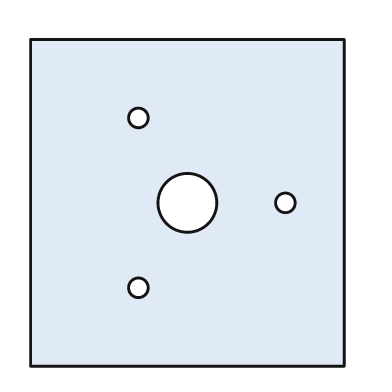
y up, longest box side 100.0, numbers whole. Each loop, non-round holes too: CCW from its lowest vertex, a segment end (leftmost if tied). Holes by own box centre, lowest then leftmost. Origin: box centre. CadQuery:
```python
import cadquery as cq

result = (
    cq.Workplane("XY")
    .moveTo(-48.0, -50.0)
    .lineTo(48.0, -50.0)
    .lineTo(48.0, 50.0)
    .lineTo(-48.0, 50.0)
    .close()
    .moveTo(-15.0, -26.0)
    .circle(3.0)
    .moveTo(0.0, 0.0)
    .circle(9.0)
    .moveTo(30.0, 0.0)
    .circle(3.0)
    .moveTo(-15.0, 26.0)
    .circle(3.0)
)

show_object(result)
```